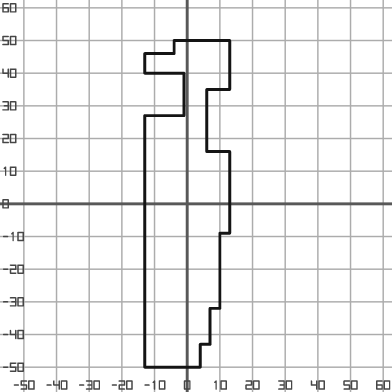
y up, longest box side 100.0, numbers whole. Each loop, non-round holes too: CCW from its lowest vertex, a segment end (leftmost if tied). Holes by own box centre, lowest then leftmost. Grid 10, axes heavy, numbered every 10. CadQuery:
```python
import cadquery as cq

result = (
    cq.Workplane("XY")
    .moveTo(-13.0, -50.0)
    .lineTo(4.0, -50.0)
    .lineTo(4.0, -43.0)
    .lineTo(7.0, -43.0)
    .lineTo(7.0, -32.0)
    .lineTo(10.0, -32.0)
    .lineTo(10.0, -9.0)
    .lineTo(13.0, -9.0)
    .lineTo(13.0, 16.0)
    .lineTo(6.0, 16.0)
    .lineTo(6.0, 35.0)
    .lineTo(13.0, 35.0)
    .lineTo(13.0, 50.0)
    .lineTo(-4.0, 50.0)
    .lineTo(-4.0, 46.0)
    .lineTo(-13.0, 46.0)
    .lineTo(-13.0, 40.0)
    .lineTo(-1.0, 40.0)
    .lineTo(-1.0, 27.0)
    .lineTo(-13.0, 27.0)
    .close()
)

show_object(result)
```